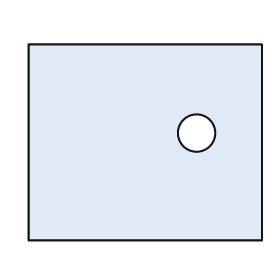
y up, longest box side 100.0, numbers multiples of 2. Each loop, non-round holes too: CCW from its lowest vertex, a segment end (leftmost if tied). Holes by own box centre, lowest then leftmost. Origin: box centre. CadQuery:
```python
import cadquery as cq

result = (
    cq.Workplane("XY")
    .moveTo(-50.0, -42.0)
    .lineTo(50.0, -42.0)
    .lineTo(50.0, 42.0)
    .lineTo(-50.0, 42.0)
    .close()
    .moveTo(22.0, 4.0)
    .circle(8.0)
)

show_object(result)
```